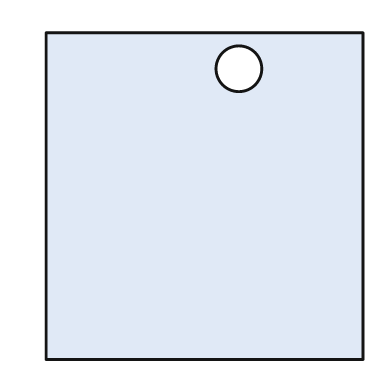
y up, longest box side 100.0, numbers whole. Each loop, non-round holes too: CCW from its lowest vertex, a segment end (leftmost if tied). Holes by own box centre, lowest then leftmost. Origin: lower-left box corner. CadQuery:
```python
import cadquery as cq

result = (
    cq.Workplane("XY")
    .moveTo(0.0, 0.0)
    .lineTo(97.0, 0.0)
    .lineTo(97.0, 100.0)
    .lineTo(0.0, 100.0)
    .close()
    .moveTo(59.0, 89.0)
    .circle(7.0)
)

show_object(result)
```